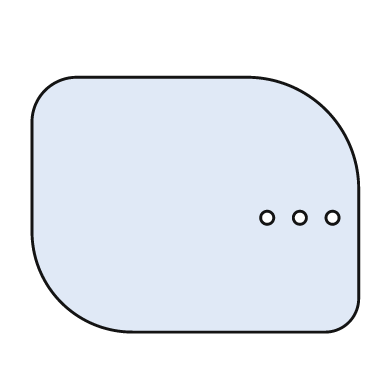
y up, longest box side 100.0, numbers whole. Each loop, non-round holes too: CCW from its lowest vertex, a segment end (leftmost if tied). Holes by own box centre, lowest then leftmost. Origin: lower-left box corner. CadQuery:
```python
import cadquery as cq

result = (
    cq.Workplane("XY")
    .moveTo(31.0, 0.0)
    .lineTo(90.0, 0.0)
    .threePointArc((97.0, 3.0), (100.0, 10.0))
    .lineTo(100.0, 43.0)
    .threePointArc((90.0, 68.0), (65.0, 78.0))
    .lineTo(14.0, 78.0)
    .threePointArc((4.0, 74.0), (0.0, 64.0))
    .lineTo(0.0, 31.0)
    .threePointArc((9.0, 9.0), (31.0, 0.0))
    .close()
    .moveTo(72.0, 35.0)
    .circle(2.0)
    .moveTo(82.0, 35.0)
    .circle(2.0)
    .moveTo(92.0, 35.0)
    .circle(2.0)
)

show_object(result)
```